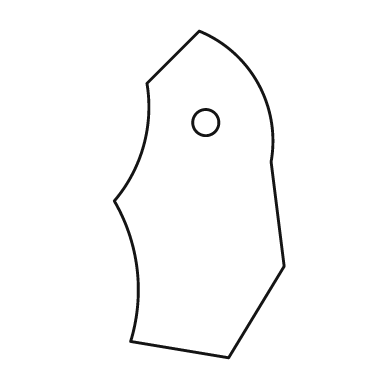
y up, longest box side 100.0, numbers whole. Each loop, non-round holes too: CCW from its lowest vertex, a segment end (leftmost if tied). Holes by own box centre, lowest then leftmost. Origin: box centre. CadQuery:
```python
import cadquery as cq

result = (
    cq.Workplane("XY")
    .moveTo(9.0, -50.0)
    .lineTo(26.0, -22.0)
    .lineTo(22.0, 10.0)
    .threePointArc((18.0, 34.0), (0.0, 50.0))
    .lineTo(-16.0, 34.0)
    .threePointArc((-17.0, 15.0), (-26.0, -2.0))
    .threePointArc((-19.0, -23.0), (-21.0, -45.0))
    .close()
    .moveTo(2.0, 22.0)
    .circle(4.0)
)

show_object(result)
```